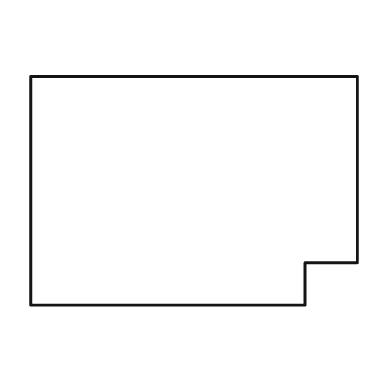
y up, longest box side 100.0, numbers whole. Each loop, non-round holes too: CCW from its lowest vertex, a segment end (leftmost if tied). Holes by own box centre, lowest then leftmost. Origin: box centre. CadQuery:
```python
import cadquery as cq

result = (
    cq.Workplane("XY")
    .moveTo(-50.0, -35.0)
    .lineTo(34.0, -35.0)
    .lineTo(34.0, -22.0)
    .lineTo(50.0, -22.0)
    .lineTo(50.0, 35.0)
    .lineTo(-50.0, 35.0)
    .close()
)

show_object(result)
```